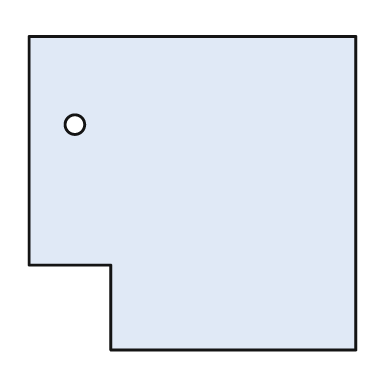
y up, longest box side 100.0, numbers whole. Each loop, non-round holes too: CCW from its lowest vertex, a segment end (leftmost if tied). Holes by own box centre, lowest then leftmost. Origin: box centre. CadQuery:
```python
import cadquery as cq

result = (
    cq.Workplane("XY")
    .moveTo(-25.0, -48.0)
    .lineTo(50.0, -48.0)
    .lineTo(50.0, 48.0)
    .lineTo(-50.0, 48.0)
    .lineTo(-50.0, -22.0)
    .lineTo(-25.0, -22.0)
    .close()
    .moveTo(-36.0, 21.0)
    .circle(3.0)
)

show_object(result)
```